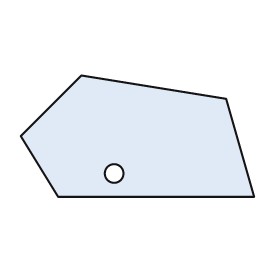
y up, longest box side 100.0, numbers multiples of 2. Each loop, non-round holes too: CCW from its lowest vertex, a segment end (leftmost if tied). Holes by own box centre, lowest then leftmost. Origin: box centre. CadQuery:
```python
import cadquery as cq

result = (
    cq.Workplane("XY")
    .moveTo(-34.0, -26.0)
    .lineTo(50.0, -26.0)
    .lineTo(38.0, 16.0)
    .lineTo(-24.0, 26.0)
    .lineTo(-50.0, 0.0)
    .close()
    .moveTo(-10.0, -16.0)
    .circle(4.0)
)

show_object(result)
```